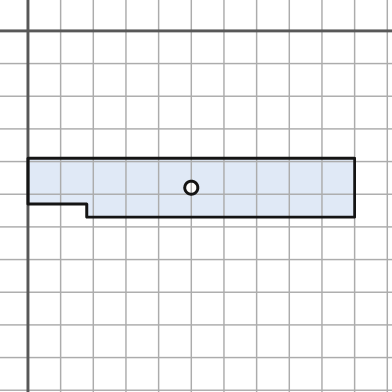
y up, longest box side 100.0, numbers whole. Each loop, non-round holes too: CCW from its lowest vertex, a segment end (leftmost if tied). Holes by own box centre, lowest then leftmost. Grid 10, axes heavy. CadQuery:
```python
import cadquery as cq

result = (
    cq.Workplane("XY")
    .moveTo(18.0, -57.0)
    .lineTo(100.0, -57.0)
    .lineTo(100.0, -39.0)
    .lineTo(0.0, -39.0)
    .lineTo(0.0, -53.0)
    .lineTo(18.0, -53.0)
    .close()
    .moveTo(50.0, -48.0)
    .circle(2.0)
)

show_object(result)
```